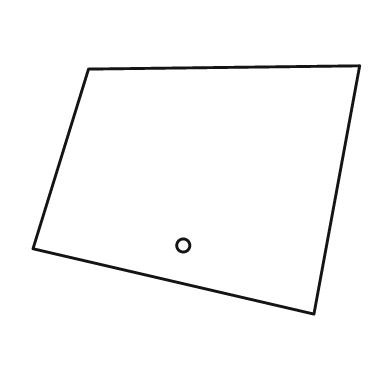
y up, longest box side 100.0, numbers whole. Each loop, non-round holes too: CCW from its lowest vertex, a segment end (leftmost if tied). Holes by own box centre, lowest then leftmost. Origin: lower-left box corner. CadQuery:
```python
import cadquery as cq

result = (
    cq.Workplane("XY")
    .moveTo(86.0, 0.0)
    .lineTo(100.0, 76.0)
    .lineTo(17.0, 75.0)
    .lineTo(0.0, 20.0)
    .close()
    .moveTo(46.0, 21.0)
    .circle(2.0)
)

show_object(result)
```